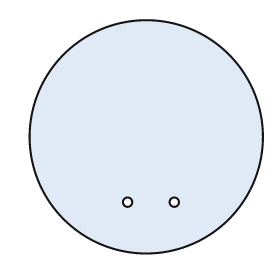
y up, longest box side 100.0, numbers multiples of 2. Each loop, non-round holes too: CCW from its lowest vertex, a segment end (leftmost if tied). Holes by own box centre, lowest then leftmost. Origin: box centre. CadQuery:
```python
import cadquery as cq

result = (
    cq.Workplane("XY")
    .moveTo(0.0, 0.0)
    .circle(50.0)
    .moveTo(-8.0, -28.0)
    .circle(2.0)
    .moveTo(12.0, -28.0)
    .circle(2.0)
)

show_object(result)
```